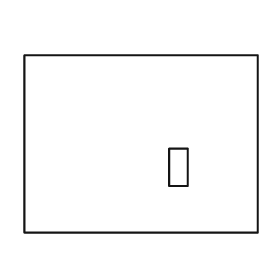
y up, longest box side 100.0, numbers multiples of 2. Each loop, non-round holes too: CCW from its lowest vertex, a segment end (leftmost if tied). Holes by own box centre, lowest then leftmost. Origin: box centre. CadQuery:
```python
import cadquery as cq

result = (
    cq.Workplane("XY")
    .moveTo(-50.0, -38.0)
    .lineTo(50.0, -38.0)
    .lineTo(50.0, 38.0)
    .lineTo(-50.0, 38.0)
    .close()
    .moveTo(12.0, -18.0)
    .lineTo(20.0, -18.0)
    .lineTo(20.0, -2.0)
    .lineTo(12.0, -2.0)
    .close()
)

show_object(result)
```